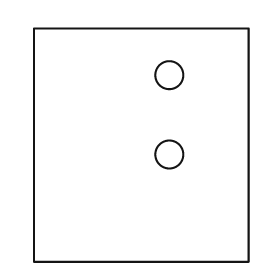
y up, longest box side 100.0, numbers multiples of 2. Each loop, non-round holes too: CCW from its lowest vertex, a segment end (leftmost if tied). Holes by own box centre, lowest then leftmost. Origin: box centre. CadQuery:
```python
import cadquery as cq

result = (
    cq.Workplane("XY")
    .moveTo(-46.0, -50.0)
    .lineTo(46.0, -50.0)
    .lineTo(46.0, 50.0)
    .lineTo(-46.0, 50.0)
    .close()
    .moveTo(12.0, -4.0)
    .circle(6.0)
    .moveTo(12.0, 30.0)
    .circle(6.0)
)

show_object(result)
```